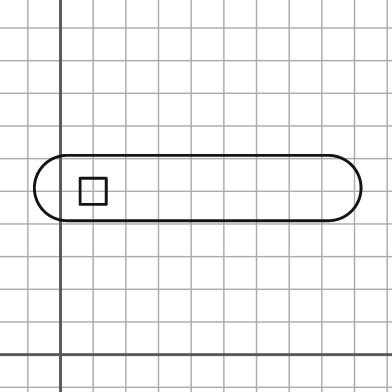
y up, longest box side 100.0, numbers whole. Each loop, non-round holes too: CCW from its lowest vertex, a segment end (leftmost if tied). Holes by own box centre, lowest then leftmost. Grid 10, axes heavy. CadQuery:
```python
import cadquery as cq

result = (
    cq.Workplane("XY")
    .moveTo(2.0, 41.0)
    .lineTo(82.0, 41.0)
    .threePointArc((92.0, 51.0), (82.0, 61.0))
    .lineTo(2.0, 61.0)
    .threePointArc((-8.0, 51.0), (2.0, 41.0))
    .close()
    .moveTo(6.0, 46.0)
    .lineTo(14.0, 46.0)
    .lineTo(14.0, 54.0)
    .lineTo(6.0, 54.0)
    .close()
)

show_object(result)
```